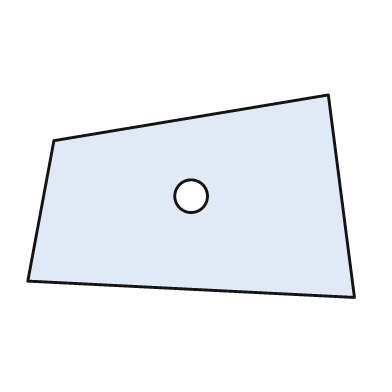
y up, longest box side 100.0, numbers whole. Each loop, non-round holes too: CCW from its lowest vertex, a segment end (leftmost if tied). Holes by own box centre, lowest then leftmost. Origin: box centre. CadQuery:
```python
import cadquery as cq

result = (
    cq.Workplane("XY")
    .moveTo(50.0, -31.0)
    .lineTo(42.0, 31.0)
    .lineTo(-42.0, 17.0)
    .lineTo(-50.0, -26.0)
    .close()
    .moveTo(0.0, 0.0)
    .circle(5.0)
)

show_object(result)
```